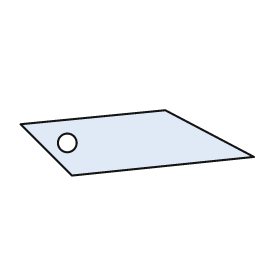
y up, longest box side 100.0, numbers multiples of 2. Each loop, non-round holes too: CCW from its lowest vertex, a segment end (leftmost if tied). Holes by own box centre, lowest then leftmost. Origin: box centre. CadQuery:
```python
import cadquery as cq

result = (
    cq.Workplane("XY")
    .moveTo(-28.0, -14.0)
    .lineTo(50.0, -6.0)
    .lineTo(12.0, 14.0)
    .lineTo(-50.0, 8.0)
    .close()
    .moveTo(-30.0, 0.0)
    .circle(4.0)
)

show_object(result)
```